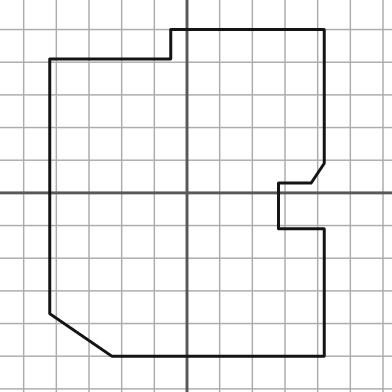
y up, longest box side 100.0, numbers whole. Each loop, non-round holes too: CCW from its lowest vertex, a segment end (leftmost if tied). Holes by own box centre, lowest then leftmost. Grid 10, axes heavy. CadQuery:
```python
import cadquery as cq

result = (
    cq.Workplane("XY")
    .moveTo(-23.0, -50.0)
    .lineTo(42.0, -50.0)
    .lineTo(42.0, -11.0)
    .lineTo(28.0, -11.0)
    .lineTo(28.0, 3.0)
    .lineTo(38.0, 3.0)
    .lineTo(42.0, 9.0)
    .lineTo(42.0, 50.0)
    .lineTo(-5.0, 50.0)
    .lineTo(-5.0, 41.0)
    .lineTo(-42.0, 41.0)
    .lineTo(-42.0, -37.0)
    .close()
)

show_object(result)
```